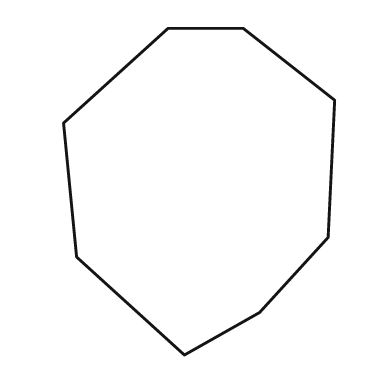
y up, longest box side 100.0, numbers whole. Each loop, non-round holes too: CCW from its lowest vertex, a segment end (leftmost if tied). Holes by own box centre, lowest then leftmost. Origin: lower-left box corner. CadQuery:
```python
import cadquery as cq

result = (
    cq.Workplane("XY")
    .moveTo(37.0, 0.0)
    .lineTo(60.0, 13.0)
    .lineTo(81.0, 36.0)
    .lineTo(83.0, 78.0)
    .lineTo(55.0, 100.0)
    .lineTo(32.0, 100.0)
    .lineTo(0.0, 71.0)
    .lineTo(4.0, 30.0)
    .close()
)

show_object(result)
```